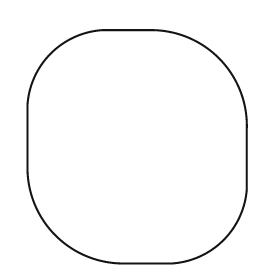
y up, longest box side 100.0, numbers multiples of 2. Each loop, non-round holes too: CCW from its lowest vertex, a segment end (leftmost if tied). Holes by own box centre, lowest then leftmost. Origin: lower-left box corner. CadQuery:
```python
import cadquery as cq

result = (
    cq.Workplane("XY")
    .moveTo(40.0, 0.0)
    .lineTo(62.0, 0.0)
    .threePointArc((84.0, 10.0), (94.0, 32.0))
    .lineTo(94.0, 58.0)
    .threePointArc((82.0, 88.0), (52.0, 100.0))
    .lineTo(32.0, 100.0)
    .threePointArc((10.0, 90.0), (0.0, 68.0))
    .lineTo(0.0, 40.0)
    .threePointArc((12.0, 12.0), (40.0, 0.0))
    .close()
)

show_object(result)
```